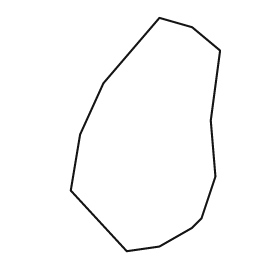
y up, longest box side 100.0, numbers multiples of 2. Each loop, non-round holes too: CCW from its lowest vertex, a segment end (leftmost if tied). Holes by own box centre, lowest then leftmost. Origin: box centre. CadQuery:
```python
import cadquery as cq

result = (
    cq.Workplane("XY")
    .moveTo(-8.0, -50.0)
    .lineTo(6.0, -48.0)
    .lineTo(20.0, -40.0)
    .lineTo(24.0, -36.0)
    .lineTo(30.0, -18.0)
    .lineTo(28.0, 6.0)
    .lineTo(32.0, 36.0)
    .lineTo(20.0, 46.0)
    .lineTo(6.0, 50.0)
    .lineTo(-18.0, 22.0)
    .lineTo(-28.0, 0.0)
    .lineTo(-32.0, -24.0)
    .close()
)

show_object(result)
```